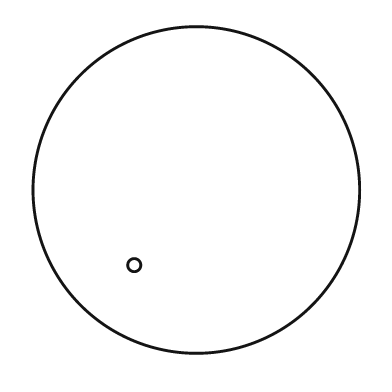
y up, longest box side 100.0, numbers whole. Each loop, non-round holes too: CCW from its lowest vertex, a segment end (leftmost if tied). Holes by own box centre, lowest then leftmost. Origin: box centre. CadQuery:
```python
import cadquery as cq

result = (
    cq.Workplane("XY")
    .moveTo(0.0, 0.0)
    .circle(50.0)
    .moveTo(-19.0, -23.0)
    .circle(2.0)
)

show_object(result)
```